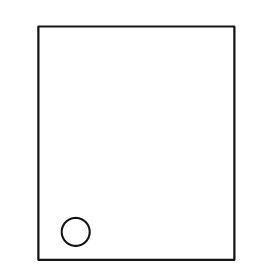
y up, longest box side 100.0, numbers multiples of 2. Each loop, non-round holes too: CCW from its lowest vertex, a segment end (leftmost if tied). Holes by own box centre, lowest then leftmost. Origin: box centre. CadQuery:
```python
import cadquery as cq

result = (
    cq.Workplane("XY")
    .moveTo(-42.0, -50.0)
    .lineTo(42.0, -50.0)
    .lineTo(42.0, 50.0)
    .lineTo(-42.0, 50.0)
    .close()
    .moveTo(-26.0, -38.0)
    .circle(6.0)
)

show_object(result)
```